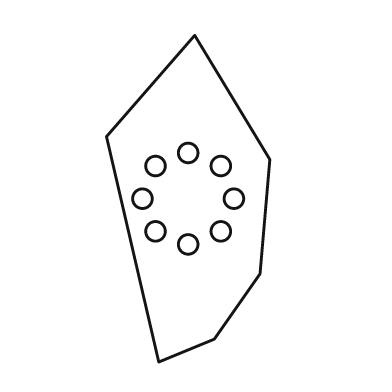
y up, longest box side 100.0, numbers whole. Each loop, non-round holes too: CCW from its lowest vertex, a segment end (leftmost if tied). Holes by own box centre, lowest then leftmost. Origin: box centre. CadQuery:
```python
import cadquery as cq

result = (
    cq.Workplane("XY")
    .moveTo(-9.0, -50.0)
    .lineTo(8.0, -43.0)
    .lineTo(22.0, -23.0)
    .lineTo(25.0, 12.0)
    .lineTo(2.0, 50.0)
    .lineTo(-25.0, 19.0)
    .close()
    .moveTo(0.0, -14.0)
    .circle(3.0)
    .moveTo(-10.0, -10.0)
    .circle(3.0)
    .moveTo(10.0, -10.0)
    .circle(3.0)
    .moveTo(-14.0, 0.0)
    .circle(3.0)
    .moveTo(14.0, 0.0)
    .circle(3.0)
    .moveTo(-10.0, 10.0)
    .circle(3.0)
    .moveTo(10.0, 10.0)
    .circle(3.0)
    .moveTo(0.0, 14.0)
    .circle(3.0)
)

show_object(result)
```